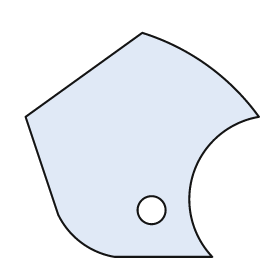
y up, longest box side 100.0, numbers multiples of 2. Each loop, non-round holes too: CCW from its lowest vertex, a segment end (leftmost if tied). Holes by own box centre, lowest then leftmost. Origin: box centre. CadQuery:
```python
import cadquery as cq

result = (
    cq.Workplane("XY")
    .moveTo(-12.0, -48.0)
    .lineTo(30.0, -48.0)
    .threePointArc((22.0, -12.0), (50.0, 12.0))
    .threePointArc((28.0, 34.0), (0.0, 48.0))
    .lineTo(-50.0, 12.0)
    .lineTo(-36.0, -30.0)
    .threePointArc((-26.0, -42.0), (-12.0, -48.0))
    .close()
    .moveTo(4.0, -28.0)
    .circle(6.0)
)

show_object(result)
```